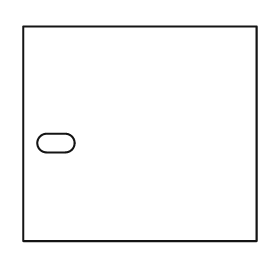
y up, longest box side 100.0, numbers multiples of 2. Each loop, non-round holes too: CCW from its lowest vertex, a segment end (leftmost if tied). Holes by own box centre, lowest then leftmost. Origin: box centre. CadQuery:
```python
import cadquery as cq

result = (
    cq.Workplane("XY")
    .moveTo(-50.0, -46.0)
    .lineTo(50.0, -46.0)
    .lineTo(50.0, 46.0)
    .lineTo(-50.0, 46.0)
    .close()
    .moveTo(-40.0, -8.0)
    .lineTo(-32.0, -8.0)
    .threePointArc((-28.0, -4.0), (-32.0, 0.0))
    .lineTo(-40.0, 0.0)
    .threePointArc((-44.0, -4.0), (-40.0, -8.0))
    .close()
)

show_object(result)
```